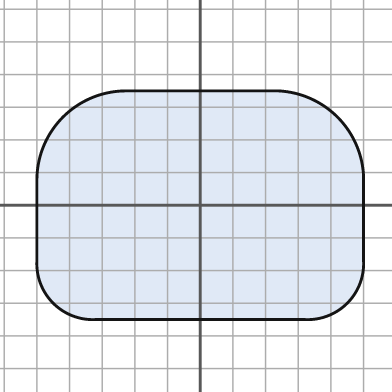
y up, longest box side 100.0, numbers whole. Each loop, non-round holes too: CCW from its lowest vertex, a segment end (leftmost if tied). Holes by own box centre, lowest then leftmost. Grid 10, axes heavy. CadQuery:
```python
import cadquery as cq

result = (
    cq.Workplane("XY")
    .moveTo(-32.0, -35.0)
    .lineTo(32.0, -35.0)
    .threePointArc((45.0, -30.0), (50.0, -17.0))
    .lineTo(50.0, 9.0)
    .threePointArc((42.0, 27.0), (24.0, 35.0))
    .lineTo(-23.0, 35.0)
    .threePointArc((-42.0, 27.0), (-50.0, 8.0))
    .lineTo(-50.0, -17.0)
    .threePointArc((-45.0, -30.0), (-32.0, -35.0))
    .close()
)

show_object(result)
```